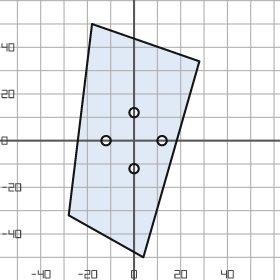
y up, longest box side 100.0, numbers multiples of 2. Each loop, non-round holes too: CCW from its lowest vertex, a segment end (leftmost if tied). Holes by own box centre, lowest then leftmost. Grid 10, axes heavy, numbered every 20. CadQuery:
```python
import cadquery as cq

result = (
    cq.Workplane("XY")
    .moveTo(4.0, -50.0)
    .lineTo(28.0, 34.0)
    .lineTo(-18.0, 50.0)
    .lineTo(-28.0, -32.0)
    .close()
    .moveTo(0.0, -12.0)
    .circle(2.0)
    .moveTo(-12.0, 0.0)
    .circle(2.0)
    .moveTo(12.0, 0.0)
    .circle(2.0)
    .moveTo(0.0, 12.0)
    .circle(2.0)
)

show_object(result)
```